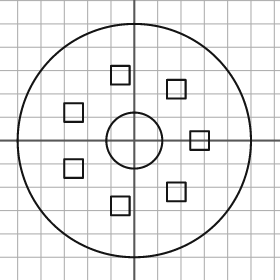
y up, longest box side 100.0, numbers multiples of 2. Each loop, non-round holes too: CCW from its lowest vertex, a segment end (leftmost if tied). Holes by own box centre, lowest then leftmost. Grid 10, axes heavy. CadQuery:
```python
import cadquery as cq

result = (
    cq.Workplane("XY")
    .moveTo(0.0, 0.0)
    .circle(50.0)
    .moveTo(-10.0, -32.0)
    .lineTo(-2.0, -32.0)
    .lineTo(-2.0, -24.0)
    .lineTo(-10.0, -24.0)
    .close()
    .moveTo(14.0, -26.0)
    .lineTo(22.0, -26.0)
    .lineTo(22.0, -18.0)
    .lineTo(14.0, -18.0)
    .close()
    .moveTo(-30.0, -16.0)
    .lineTo(-22.0, -16.0)
    .lineTo(-22.0, -8.0)
    .lineTo(-30.0, -8.0)
    .close()
    .moveTo(0.0, 0.0)
    .circle(12.0)
    .moveTo(24.0, -4.0)
    .lineTo(32.0, -4.0)
    .lineTo(32.0, 4.0)
    .lineTo(24.0, 4.0)
    .close()
    .moveTo(-30.0, 8.0)
    .lineTo(-22.0, 8.0)
    .lineTo(-22.0, 16.0)
    .lineTo(-30.0, 16.0)
    .close()
    .moveTo(14.0, 18.0)
    .lineTo(22.0, 18.0)
    .lineTo(22.0, 26.0)
    .lineTo(14.0, 26.0)
    .close()
    .moveTo(-10.0, 24.0)
    .lineTo(-2.0, 24.0)
    .lineTo(-2.0, 32.0)
    .lineTo(-10.0, 32.0)
    .close()
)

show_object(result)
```